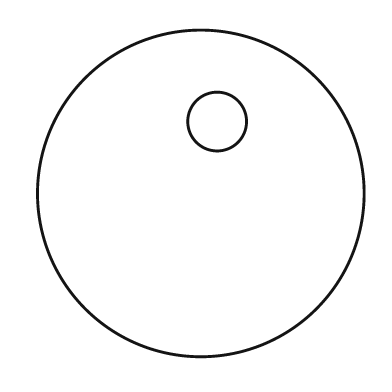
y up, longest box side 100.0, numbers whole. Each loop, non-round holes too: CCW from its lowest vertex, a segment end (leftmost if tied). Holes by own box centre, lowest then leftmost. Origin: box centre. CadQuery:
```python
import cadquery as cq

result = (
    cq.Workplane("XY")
    .moveTo(0.0, 0.0)
    .circle(50.0)
    .moveTo(5.0, 22.0)
    .circle(9.0)
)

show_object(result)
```